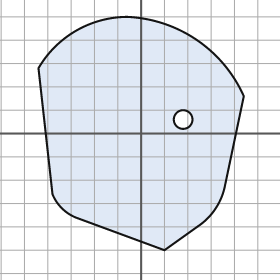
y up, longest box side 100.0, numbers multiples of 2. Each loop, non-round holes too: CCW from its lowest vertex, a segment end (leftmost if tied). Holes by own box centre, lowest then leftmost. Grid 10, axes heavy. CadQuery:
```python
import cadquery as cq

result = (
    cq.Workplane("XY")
    .moveTo(10.0, -50.0)
    .lineTo(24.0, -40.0)
    .threePointArc((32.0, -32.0), (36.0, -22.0))
    .lineTo(44.0, 16.0)
    .threePointArc((24.0, 40.0), (-6.0, 50.0))
    .threePointArc((-28.0, 44.0), (-44.0, 28.0))
    .lineTo(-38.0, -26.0)
    .threePointArc((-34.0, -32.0), (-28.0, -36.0))
    .close()
    .moveTo(18.0, 6.0)
    .circle(4.0)
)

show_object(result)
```